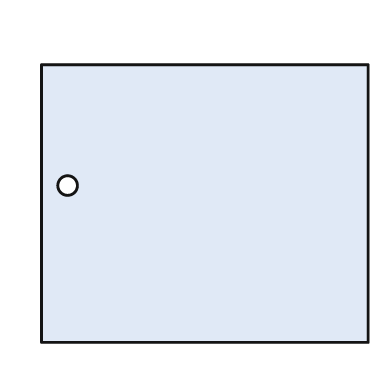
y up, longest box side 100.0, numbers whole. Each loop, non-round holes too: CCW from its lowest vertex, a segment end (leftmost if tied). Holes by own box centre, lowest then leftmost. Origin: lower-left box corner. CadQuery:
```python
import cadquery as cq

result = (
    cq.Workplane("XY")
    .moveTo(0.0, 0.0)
    .lineTo(100.0, 0.0)
    .lineTo(100.0, 85.0)
    .lineTo(0.0, 85.0)
    .close()
    .moveTo(8.0, 48.0)
    .circle(3.0)
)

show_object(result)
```